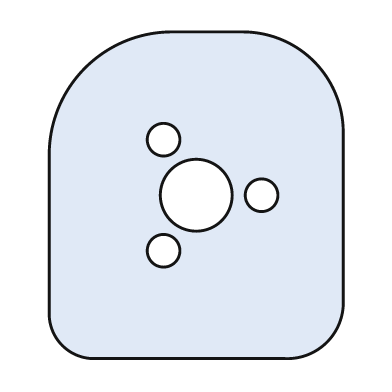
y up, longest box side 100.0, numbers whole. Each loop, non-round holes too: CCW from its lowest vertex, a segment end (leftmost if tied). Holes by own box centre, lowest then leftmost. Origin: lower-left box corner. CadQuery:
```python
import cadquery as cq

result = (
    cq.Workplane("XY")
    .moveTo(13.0, 0.0)
    .lineTo(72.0, 0.0)
    .threePointArc((85.0, 5.0), (90.0, 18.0))
    .lineTo(90.0, 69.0)
    .threePointArc((81.0, 91.0), (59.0, 100.0))
    .lineTo(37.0, 100.0)
    .threePointArc((11.0, 89.0), (0.0, 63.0))
    .lineTo(0.0, 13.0)
    .threePointArc((4.0, 4.0), (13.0, 0.0))
    .close()
    .moveTo(35.0, 33.0)
    .circle(5.0)
    .moveTo(45.0, 50.0)
    .circle(11.0)
    .moveTo(65.0, 50.0)
    .circle(5.0)
    .moveTo(35.0, 67.0)
    .circle(5.0)
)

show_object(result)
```